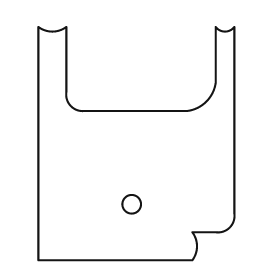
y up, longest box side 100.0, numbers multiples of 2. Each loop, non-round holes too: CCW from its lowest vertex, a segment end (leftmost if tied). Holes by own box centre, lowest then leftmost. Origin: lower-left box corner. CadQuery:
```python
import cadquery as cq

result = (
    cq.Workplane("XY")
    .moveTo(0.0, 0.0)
    .lineTo(66.0, 0.0)
    .threePointArc((68.0, 6.0), (66.0, 12.0))
    .lineTo(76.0, 12.0)
    .threePointArc((82.0, 14.0), (84.0, 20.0))
    .lineTo(84.0, 100.0)
    .threePointArc((80.0, 98.0), (76.0, 100.0))
    .lineTo(76.0, 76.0)
    .threePointArc((72.0, 68.0), (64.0, 64.0))
    .lineTo(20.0, 64.0)
    .threePointArc((14.0, 66.0), (12.0, 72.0))
    .lineTo(12.0, 100.0)
    .threePointArc((6.0, 98.0), (0.0, 100.0))
    .close()
    .moveTo(40.0, 24.0)
    .circle(4.0)
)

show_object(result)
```